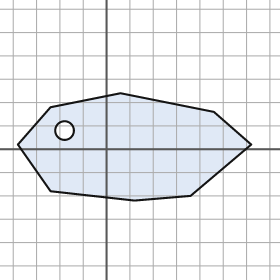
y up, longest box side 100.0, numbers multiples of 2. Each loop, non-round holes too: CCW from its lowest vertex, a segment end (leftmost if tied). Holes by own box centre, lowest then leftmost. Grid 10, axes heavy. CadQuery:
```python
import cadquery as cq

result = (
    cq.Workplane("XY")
    .moveTo(12.0, -22.0)
    .lineTo(36.0, -20.0)
    .lineTo(62.0, 2.0)
    .lineTo(46.0, 16.0)
    .lineTo(6.0, 24.0)
    .lineTo(-24.0, 18.0)
    .lineTo(-38.0, 2.0)
    .lineTo(-24.0, -18.0)
    .close()
    .moveTo(-18.0, 8.0)
    .circle(4.0)
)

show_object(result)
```